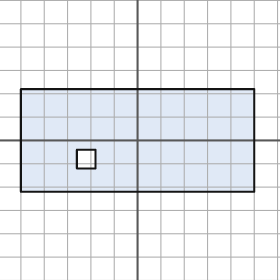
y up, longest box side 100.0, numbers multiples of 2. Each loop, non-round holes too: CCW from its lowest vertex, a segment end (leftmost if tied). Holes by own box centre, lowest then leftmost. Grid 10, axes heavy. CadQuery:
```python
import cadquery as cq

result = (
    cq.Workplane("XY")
    .moveTo(-50.0, -22.0)
    .lineTo(50.0, -22.0)
    .lineTo(50.0, 22.0)
    .lineTo(-50.0, 22.0)
    .close()
    .moveTo(-26.0, -12.0)
    .lineTo(-18.0, -12.0)
    .lineTo(-18.0, -4.0)
    .lineTo(-26.0, -4.0)
    .close()
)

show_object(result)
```